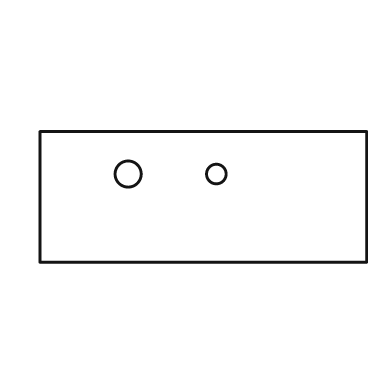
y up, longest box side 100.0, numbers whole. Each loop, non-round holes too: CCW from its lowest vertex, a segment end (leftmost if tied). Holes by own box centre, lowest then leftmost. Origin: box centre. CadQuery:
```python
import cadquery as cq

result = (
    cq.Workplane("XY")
    .moveTo(-50.0, -20.0)
    .lineTo(50.0, -20.0)
    .lineTo(50.0, 20.0)
    .lineTo(-50.0, 20.0)
    .close()
    .moveTo(-23.0, 7.0)
    .circle(4.0)
    .moveTo(4.0, 7.0)
    .circle(3.0)
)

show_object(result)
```